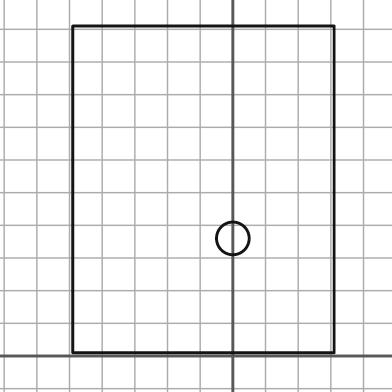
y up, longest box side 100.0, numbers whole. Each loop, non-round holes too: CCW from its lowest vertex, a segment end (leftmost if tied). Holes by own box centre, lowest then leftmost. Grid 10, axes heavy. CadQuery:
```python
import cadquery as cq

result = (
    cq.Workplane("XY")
    .moveTo(-49.0, 1.0)
    .lineTo(31.0, 1.0)
    .lineTo(31.0, 101.0)
    .lineTo(-49.0, 101.0)
    .close()
    .moveTo(0.0, 36.0)
    .circle(5.0)
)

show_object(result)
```